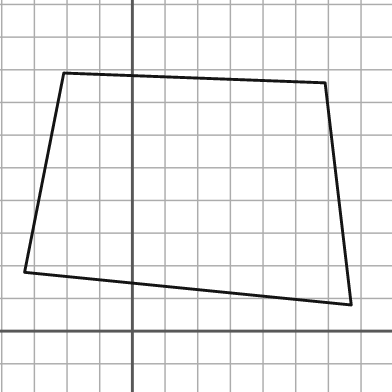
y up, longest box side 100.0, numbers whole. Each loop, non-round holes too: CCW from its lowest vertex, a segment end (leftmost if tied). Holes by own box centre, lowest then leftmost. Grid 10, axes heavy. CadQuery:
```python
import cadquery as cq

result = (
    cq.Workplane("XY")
    .moveTo(67.0, 8.0)
    .lineTo(59.0, 76.0)
    .lineTo(-21.0, 79.0)
    .lineTo(-33.0, 18.0)
    .close()
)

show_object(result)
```